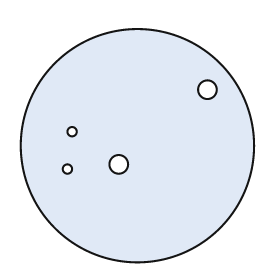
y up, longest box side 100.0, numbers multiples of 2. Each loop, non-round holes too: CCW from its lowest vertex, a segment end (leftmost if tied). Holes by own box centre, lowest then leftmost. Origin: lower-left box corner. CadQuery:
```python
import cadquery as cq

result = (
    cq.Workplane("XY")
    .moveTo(50.0, 50.0)
    .circle(50.0)
    .moveTo(20.0, 40.0)
    .circle(2.0)
    .moveTo(42.0, 42.0)
    .circle(4.0)
    .moveTo(22.0, 56.0)
    .circle(2.0)
    .moveTo(80.0, 74.0)
    .circle(4.0)
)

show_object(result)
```